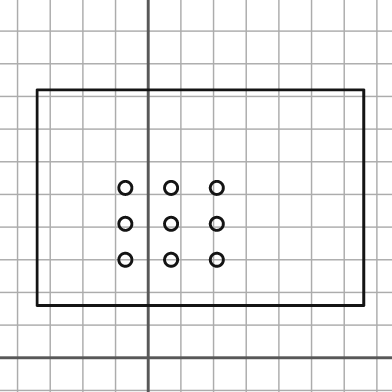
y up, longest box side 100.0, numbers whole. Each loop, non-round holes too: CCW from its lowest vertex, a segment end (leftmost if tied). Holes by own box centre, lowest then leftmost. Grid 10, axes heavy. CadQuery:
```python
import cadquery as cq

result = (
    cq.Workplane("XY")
    .moveTo(-34.0, 16.0)
    .lineTo(66.0, 16.0)
    .lineTo(66.0, 82.0)
    .lineTo(-34.0, 82.0)
    .close()
    .moveTo(-7.0, 30.0)
    .circle(2.0)
    .moveTo(7.0, 30.0)
    .circle(2.0)
    .moveTo(21.0, 30.0)
    .circle(2.0)
    .moveTo(-7.0, 41.0)
    .circle(2.0)
    .moveTo(7.0, 41.0)
    .circle(2.0)
    .moveTo(21.0, 41.0)
    .circle(2.0)
    .moveTo(-7.0, 52.0)
    .circle(2.0)
    .moveTo(7.0, 52.0)
    .circle(2.0)
    .moveTo(21.0, 52.0)
    .circle(2.0)
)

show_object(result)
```